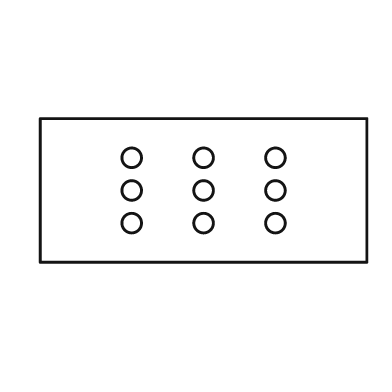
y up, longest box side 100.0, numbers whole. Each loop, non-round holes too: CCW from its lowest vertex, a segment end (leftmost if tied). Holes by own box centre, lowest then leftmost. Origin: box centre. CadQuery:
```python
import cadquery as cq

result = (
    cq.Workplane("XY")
    .moveTo(-50.0, -22.0)
    .lineTo(50.0, -22.0)
    .lineTo(50.0, 22.0)
    .lineTo(-50.0, 22.0)
    .close()
    .moveTo(-22.0, -10.0)
    .circle(3.0)
    .moveTo(0.0, -10.0)
    .circle(3.0)
    .moveTo(22.0, -10.0)
    .circle(3.0)
    .moveTo(-22.0, 0.0)
    .circle(3.0)
    .moveTo(0.0, 0.0)
    .circle(3.0)
    .moveTo(22.0, 0.0)
    .circle(3.0)
    .moveTo(-22.0, 10.0)
    .circle(3.0)
    .moveTo(0.0, 10.0)
    .circle(3.0)
    .moveTo(22.0, 10.0)
    .circle(3.0)
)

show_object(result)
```